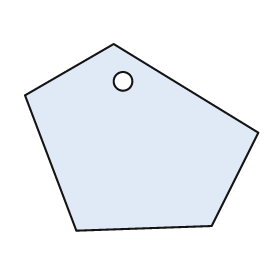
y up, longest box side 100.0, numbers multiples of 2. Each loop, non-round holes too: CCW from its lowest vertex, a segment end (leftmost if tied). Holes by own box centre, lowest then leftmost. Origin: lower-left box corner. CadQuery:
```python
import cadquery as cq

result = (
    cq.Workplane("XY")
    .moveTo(22.0, 0.0)
    .lineTo(80.0, 2.0)
    .lineTo(100.0, 42.0)
    .lineTo(38.0, 80.0)
    .lineTo(0.0, 58.0)
    .close()
    .moveTo(42.0, 64.0)
    .circle(4.0)
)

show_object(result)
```